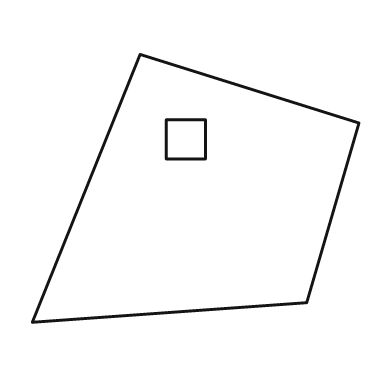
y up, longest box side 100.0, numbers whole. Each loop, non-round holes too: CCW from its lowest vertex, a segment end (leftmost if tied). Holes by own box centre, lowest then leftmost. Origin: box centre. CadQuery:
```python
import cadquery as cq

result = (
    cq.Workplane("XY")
    .moveTo(-50.0, -41.0)
    .lineTo(34.0, -35.0)
    .lineTo(50.0, 20.0)
    .lineTo(-17.0, 41.0)
    .close()
    .moveTo(-9.0, 9.0)
    .lineTo(3.0, 9.0)
    .lineTo(3.0, 21.0)
    .lineTo(-9.0, 21.0)
    .close()
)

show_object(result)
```